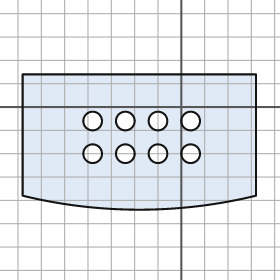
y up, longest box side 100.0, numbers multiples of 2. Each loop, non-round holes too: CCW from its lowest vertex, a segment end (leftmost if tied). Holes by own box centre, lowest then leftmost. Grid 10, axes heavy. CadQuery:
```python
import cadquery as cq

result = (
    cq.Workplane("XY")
    .moveTo(-68.0, -38.0)
    .threePointArc((-18.0, -44.0), (32.0, -38.0))
    .lineTo(32.0, 14.0)
    .lineTo(-68.0, 14.0)
    .close()
    .moveTo(-38.0, -20.0)
    .circle(4.0)
    .moveTo(-24.0, -20.0)
    .circle(4.0)
    .moveTo(-10.0, -20.0)
    .circle(4.0)
    .moveTo(4.0, -20.0)
    .circle(4.0)
    .moveTo(-38.0, -6.0)
    .circle(4.0)
    .moveTo(-24.0, -6.0)
    .circle(4.0)
    .moveTo(-10.0, -6.0)
    .circle(4.0)
    .moveTo(4.0, -6.0)
    .circle(4.0)
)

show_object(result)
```